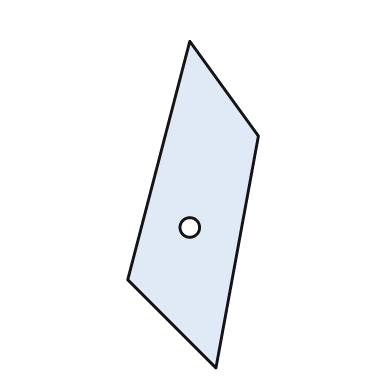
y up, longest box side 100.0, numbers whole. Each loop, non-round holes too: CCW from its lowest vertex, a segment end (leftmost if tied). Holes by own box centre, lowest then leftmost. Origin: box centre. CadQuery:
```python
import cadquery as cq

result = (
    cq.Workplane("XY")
    .moveTo(7.0, -50.0)
    .lineTo(20.0, 21.0)
    .lineTo(-1.0, 50.0)
    .lineTo(-20.0, -23.0)
    .close()
    .moveTo(-1.0, -7.0)
    .circle(3.0)
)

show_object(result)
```